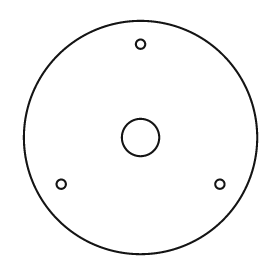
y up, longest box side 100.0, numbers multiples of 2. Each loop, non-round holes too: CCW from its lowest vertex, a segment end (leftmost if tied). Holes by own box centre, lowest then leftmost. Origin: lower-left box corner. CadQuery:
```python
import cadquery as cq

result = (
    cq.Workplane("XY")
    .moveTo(50.0, 50.0)
    .circle(50.0)
    .moveTo(16.0, 30.0)
    .circle(2.0)
    .moveTo(84.0, 30.0)
    .circle(2.0)
    .moveTo(50.0, 50.0)
    .circle(8.0)
    .moveTo(50.0, 90.0)
    .circle(2.0)
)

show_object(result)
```